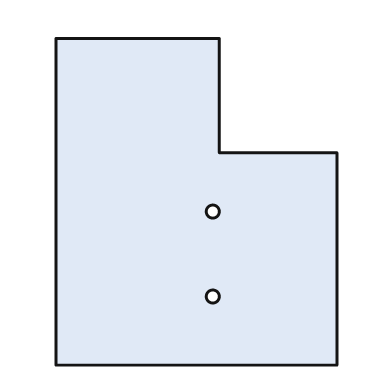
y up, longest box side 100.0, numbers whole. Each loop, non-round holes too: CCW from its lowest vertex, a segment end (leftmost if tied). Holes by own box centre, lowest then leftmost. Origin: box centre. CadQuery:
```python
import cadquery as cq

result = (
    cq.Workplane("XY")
    .moveTo(-43.0, -50.0)
    .lineTo(43.0, -50.0)
    .lineTo(43.0, 15.0)
    .lineTo(7.0, 15.0)
    .lineTo(7.0, 50.0)
    .lineTo(-43.0, 50.0)
    .close()
    .moveTo(5.0, -29.0)
    .circle(2.0)
    .moveTo(5.0, -3.0)
    .circle(2.0)
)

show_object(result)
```